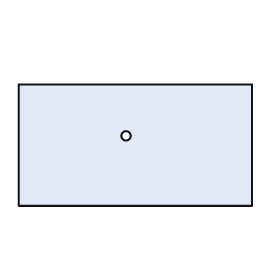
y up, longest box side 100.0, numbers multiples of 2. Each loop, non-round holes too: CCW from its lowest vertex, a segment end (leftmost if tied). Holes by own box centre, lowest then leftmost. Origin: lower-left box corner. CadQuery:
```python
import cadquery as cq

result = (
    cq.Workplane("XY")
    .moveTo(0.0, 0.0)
    .lineTo(100.0, 0.0)
    .lineTo(100.0, 52.0)
    .lineTo(0.0, 52.0)
    .close()
    .moveTo(46.0, 30.0)
    .circle(2.0)
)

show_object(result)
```